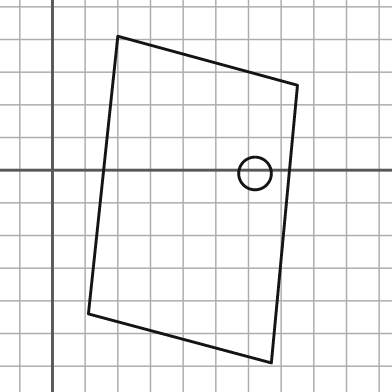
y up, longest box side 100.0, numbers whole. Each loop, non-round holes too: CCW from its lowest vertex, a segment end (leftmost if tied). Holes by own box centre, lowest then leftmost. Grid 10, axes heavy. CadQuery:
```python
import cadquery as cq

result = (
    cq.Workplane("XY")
    .moveTo(67.0, -59.0)
    .lineTo(75.0, 26.0)
    .lineTo(20.0, 41.0)
    .lineTo(11.0, -44.0)
    .close()
    .moveTo(62.0, -1.0)
    .circle(5.0)
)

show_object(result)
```